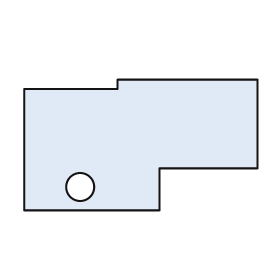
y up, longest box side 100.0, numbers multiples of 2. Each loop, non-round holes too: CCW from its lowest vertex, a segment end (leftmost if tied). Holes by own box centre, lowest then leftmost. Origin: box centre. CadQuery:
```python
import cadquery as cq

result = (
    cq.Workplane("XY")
    .moveTo(-50.0, -28.0)
    .lineTo(8.0, -28.0)
    .lineTo(8.0, -10.0)
    .lineTo(50.0, -10.0)
    .lineTo(50.0, 28.0)
    .lineTo(-10.0, 28.0)
    .lineTo(-10.0, 24.0)
    .lineTo(-50.0, 24.0)
    .close()
    .moveTo(-26.0, -18.0)
    .circle(6.0)
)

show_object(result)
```